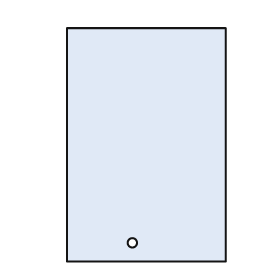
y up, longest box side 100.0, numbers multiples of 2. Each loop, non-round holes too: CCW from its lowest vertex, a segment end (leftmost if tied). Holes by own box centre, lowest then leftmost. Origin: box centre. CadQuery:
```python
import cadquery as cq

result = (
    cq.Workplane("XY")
    .moveTo(-34.0, -50.0)
    .lineTo(34.0, -50.0)
    .lineTo(34.0, 50.0)
    .lineTo(-34.0, 50.0)
    .close()
    .moveTo(-6.0, -42.0)
    .circle(2.0)
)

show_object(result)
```